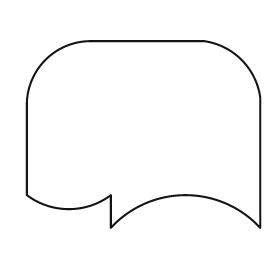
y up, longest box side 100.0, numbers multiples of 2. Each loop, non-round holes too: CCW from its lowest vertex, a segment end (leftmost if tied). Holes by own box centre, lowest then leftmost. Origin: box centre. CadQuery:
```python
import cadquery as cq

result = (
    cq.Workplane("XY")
    .moveTo(-14.0, -40.0)
    .threePointArc((18.0, -26.0), (50.0, -40.0))
    .lineTo(50.0, 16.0)
    .threePointArc((42.0, 32.0), (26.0, 40.0))
    .lineTo(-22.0, 40.0)
    .threePointArc((-42.0, 32.0), (-50.0, 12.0))
    .lineTo(-50.0, -26.0)
    .threePointArc((-32.0, -32.0), (-14.0, -26.0))
    .close()
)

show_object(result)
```